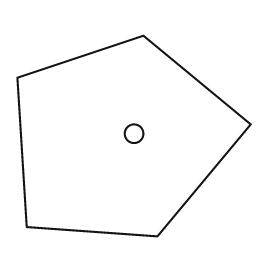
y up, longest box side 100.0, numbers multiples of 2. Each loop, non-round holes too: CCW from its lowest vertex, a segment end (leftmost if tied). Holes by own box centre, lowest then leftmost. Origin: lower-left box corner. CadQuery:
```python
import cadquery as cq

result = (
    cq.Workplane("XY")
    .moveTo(60.0, 0.0)
    .lineTo(100.0, 48.0)
    .lineTo(54.0, 86.0)
    .lineTo(0.0, 68.0)
    .lineTo(4.0, 4.0)
    .close()
    .moveTo(50.0, 44.0)
    .circle(4.0)
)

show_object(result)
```